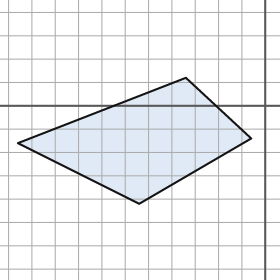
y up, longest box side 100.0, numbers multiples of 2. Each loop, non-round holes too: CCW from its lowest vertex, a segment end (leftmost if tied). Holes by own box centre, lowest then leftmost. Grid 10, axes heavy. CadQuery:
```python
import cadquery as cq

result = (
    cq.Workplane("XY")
    .moveTo(-54.0, -42.0)
    .lineTo(-6.0, -14.0)
    .lineTo(-34.0, 12.0)
    .lineTo(-106.0, -16.0)
    .close()
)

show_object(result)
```